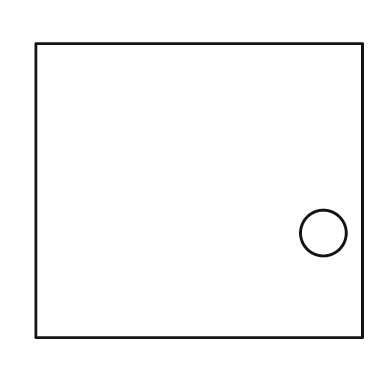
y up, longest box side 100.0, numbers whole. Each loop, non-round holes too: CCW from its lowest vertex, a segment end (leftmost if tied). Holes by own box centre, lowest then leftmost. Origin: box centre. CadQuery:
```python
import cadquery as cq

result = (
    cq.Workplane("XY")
    .moveTo(-50.0, -45.0)
    .lineTo(50.0, -45.0)
    .lineTo(50.0, 45.0)
    .lineTo(-50.0, 45.0)
    .close()
    .moveTo(38.0, -13.0)
    .circle(7.0)
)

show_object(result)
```